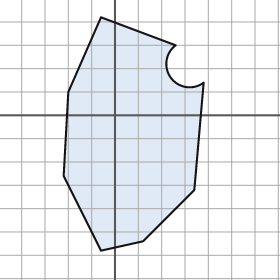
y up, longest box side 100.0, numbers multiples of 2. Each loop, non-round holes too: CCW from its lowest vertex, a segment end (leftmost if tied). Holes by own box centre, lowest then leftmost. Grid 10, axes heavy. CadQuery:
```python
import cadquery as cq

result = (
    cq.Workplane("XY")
    .moveTo(-6.0, -58.0)
    .lineTo(12.0, -54.0)
    .lineTo(34.0, -32.0)
    .lineTo(38.0, 14.0)
    .threePointArc((24.0, 16.0), (26.0, 30.0))
    .lineTo(-6.0, 42.0)
    .lineTo(-20.0, 10.0)
    .lineTo(-22.0, -26.0)
    .close()
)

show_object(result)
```